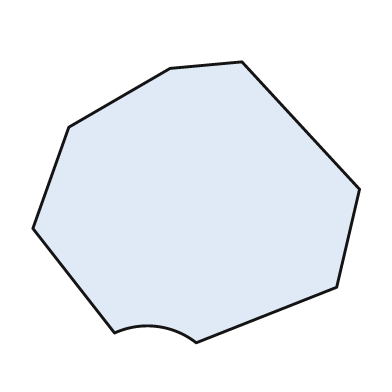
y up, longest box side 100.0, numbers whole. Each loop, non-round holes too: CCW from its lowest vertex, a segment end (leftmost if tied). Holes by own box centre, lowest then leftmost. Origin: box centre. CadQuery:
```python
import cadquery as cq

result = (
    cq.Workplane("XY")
    .moveTo(0.0, -43.0)
    .lineTo(43.0, -26.0)
    .lineTo(50.0, 4.0)
    .lineTo(14.0, 43.0)
    .lineTo(-8.0, 41.0)
    .lineTo(-39.0, 23.0)
    .lineTo(-50.0, -8.0)
    .lineTo(-25.0, -40.0)
    .threePointArc((-12.0, -38.0), (0.0, -43.0))
    .close()
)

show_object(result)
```